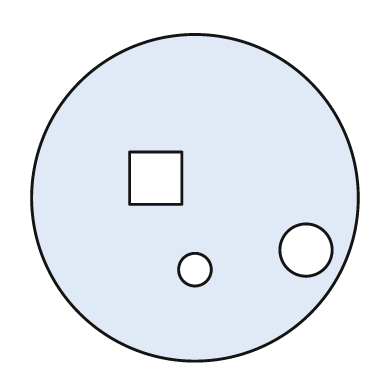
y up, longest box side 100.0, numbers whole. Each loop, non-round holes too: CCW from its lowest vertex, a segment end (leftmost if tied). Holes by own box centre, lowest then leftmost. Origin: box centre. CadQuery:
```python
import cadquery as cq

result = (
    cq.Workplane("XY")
    .moveTo(0.0, 0.0)
    .circle(50.0)
    .moveTo(0.0, -22.0)
    .circle(5.0)
    .moveTo(34.0, -16.0)
    .circle(8.0)
    .moveTo(-20.0, -2.0)
    .lineTo(-4.0, -2.0)
    .lineTo(-4.0, 14.0)
    .lineTo(-20.0, 14.0)
    .close()
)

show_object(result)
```